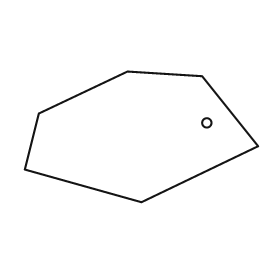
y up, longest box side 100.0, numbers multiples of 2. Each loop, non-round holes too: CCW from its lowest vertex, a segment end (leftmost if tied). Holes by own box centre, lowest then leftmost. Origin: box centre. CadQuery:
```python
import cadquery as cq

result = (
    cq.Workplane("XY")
    .moveTo(0.0, -28.0)
    .lineTo(50.0, -4.0)
    .lineTo(26.0, 26.0)
    .lineTo(-6.0, 28.0)
    .lineTo(-44.0, 10.0)
    .lineTo(-50.0, -14.0)
    .close()
    .moveTo(28.0, 6.0)
    .circle(2.0)
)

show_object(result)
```